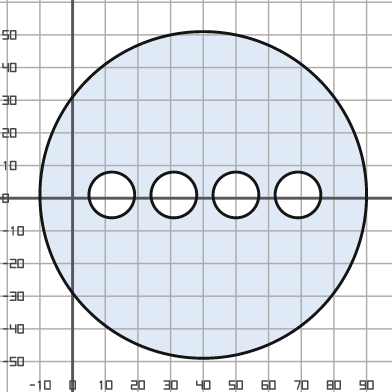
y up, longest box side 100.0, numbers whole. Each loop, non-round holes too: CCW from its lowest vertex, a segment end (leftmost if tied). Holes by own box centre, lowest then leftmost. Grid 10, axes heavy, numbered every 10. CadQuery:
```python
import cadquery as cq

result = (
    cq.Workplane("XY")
    .moveTo(40.0, 1.0)
    .circle(50.0)
    .moveTo(12.0, 1.0)
    .circle(7.0)
    .moveTo(31.0, 1.0)
    .circle(7.0)
    .moveTo(50.0, 1.0)
    .circle(7.0)
    .moveTo(69.0, 1.0)
    .circle(7.0)
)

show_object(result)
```